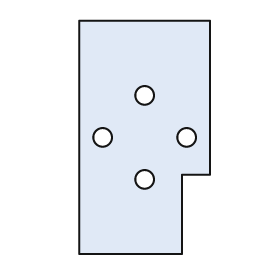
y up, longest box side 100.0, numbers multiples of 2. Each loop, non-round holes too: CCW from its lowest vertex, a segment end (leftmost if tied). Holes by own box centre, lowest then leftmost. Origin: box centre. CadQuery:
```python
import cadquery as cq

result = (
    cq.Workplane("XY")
    .moveTo(-28.0, -50.0)
    .lineTo(16.0, -50.0)
    .lineTo(16.0, -16.0)
    .lineTo(28.0, -16.0)
    .lineTo(28.0, 50.0)
    .lineTo(-28.0, 50.0)
    .close()
    .moveTo(0.0, -18.0)
    .circle(4.0)
    .moveTo(-18.0, 0.0)
    .circle(4.0)
    .moveTo(18.0, 0.0)
    .circle(4.0)
    .moveTo(0.0, 18.0)
    .circle(4.0)
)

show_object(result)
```